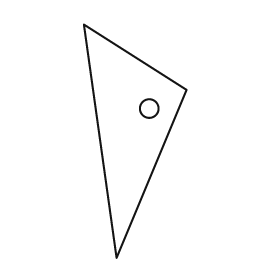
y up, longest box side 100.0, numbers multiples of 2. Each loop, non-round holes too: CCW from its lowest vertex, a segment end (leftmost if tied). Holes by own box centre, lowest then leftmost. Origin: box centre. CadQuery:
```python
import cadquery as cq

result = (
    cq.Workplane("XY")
    .moveTo(-8.0, -50.0)
    .lineTo(22.0, 22.0)
    .lineTo(-22.0, 50.0)
    .close()
    .moveTo(6.0, 14.0)
    .circle(4.0)
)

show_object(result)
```